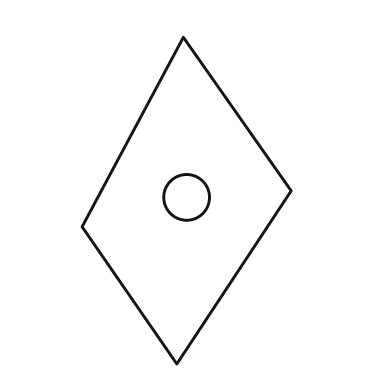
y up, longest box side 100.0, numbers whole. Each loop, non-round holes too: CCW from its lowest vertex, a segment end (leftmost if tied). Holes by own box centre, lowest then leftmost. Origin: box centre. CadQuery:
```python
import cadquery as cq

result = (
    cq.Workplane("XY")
    .moveTo(-3.0, -50.0)
    .lineTo(32.0, 3.0)
    .lineTo(-1.0, 50.0)
    .lineTo(-32.0, -8.0)
    .close()
    .moveTo(0.0, 1.0)
    .circle(7.0)
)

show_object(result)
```